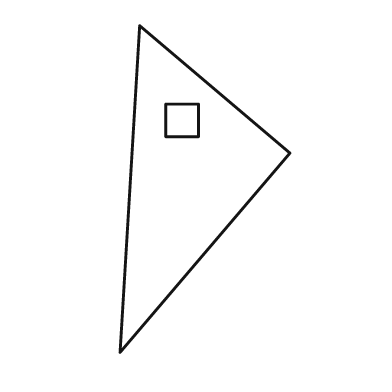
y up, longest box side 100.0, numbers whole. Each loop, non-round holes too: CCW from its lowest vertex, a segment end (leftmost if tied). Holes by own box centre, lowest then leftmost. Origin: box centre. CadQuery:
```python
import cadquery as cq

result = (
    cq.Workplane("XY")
    .moveTo(-26.0, -50.0)
    .lineTo(26.0, 11.0)
    .lineTo(-20.0, 50.0)
    .close()
    .moveTo(-12.0, 16.0)
    .lineTo(-2.0, 16.0)
    .lineTo(-2.0, 26.0)
    .lineTo(-12.0, 26.0)
    .close()
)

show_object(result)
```